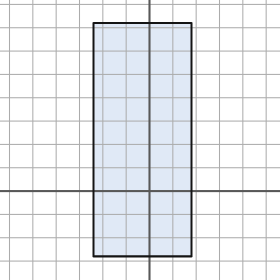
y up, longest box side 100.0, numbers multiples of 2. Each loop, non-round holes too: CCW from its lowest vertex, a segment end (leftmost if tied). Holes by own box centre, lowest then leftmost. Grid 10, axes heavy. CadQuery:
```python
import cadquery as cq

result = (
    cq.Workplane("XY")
    .moveTo(-24.0, -28.0)
    .lineTo(18.0, -28.0)
    .lineTo(18.0, 72.0)
    .lineTo(-24.0, 72.0)
    .close()
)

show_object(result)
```